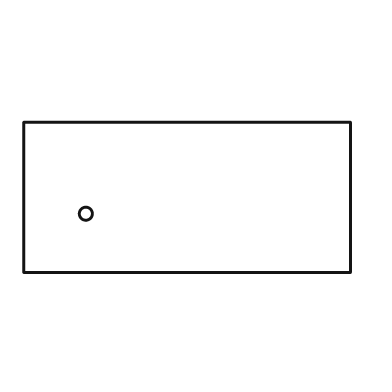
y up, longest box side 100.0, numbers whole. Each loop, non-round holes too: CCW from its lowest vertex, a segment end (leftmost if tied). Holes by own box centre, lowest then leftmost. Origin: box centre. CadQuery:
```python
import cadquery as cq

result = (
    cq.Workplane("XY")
    .moveTo(-50.0, -23.0)
    .lineTo(50.0, -23.0)
    .lineTo(50.0, 23.0)
    .lineTo(-50.0, 23.0)
    .close()
    .moveTo(-31.0, -5.0)
    .circle(2.0)
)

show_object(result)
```